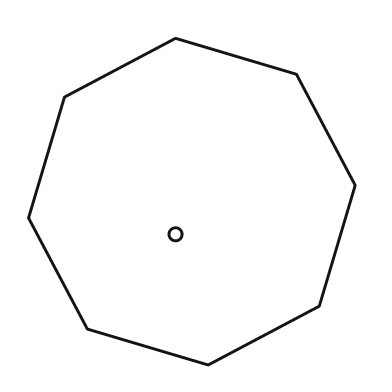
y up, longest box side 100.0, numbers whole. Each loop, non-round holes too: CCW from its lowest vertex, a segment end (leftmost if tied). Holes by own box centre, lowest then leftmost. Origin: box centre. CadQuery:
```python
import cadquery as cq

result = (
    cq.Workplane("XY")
    .moveTo(5.0, -50.0)
    .lineTo(39.0, -32.0)
    .lineTo(50.0, 5.0)
    .lineTo(32.0, 39.0)
    .lineTo(-5.0, 50.0)
    .lineTo(-39.0, 32.0)
    .lineTo(-50.0, -5.0)
    .lineTo(-32.0, -39.0)
    .close()
    .moveTo(-5.0, -10.0)
    .circle(2.0)
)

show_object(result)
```